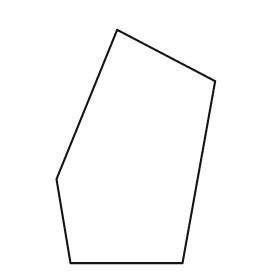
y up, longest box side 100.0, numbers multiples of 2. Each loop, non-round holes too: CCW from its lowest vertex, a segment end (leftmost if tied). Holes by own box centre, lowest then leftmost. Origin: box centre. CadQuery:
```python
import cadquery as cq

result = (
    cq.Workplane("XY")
    .moveTo(-28.0, -50.0)
    .lineTo(20.0, -50.0)
    .lineTo(34.0, 28.0)
    .lineTo(-8.0, 50.0)
    .lineTo(-34.0, -14.0)
    .close()
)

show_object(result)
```